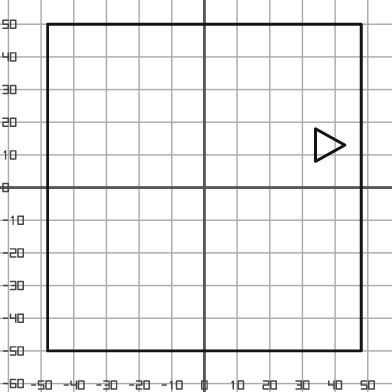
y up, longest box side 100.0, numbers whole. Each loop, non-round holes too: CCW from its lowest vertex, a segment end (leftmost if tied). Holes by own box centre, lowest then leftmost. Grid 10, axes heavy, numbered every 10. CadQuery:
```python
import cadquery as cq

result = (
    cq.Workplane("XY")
    .moveTo(-48.0, -50.0)
    .lineTo(48.0, -50.0)
    .lineTo(48.0, 50.0)
    .lineTo(-48.0, 50.0)
    .close()
    .moveTo(34.0, 8.0)
    .lineTo(43.0, 13.0)
    .lineTo(34.0, 18.0)
    .close()
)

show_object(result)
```